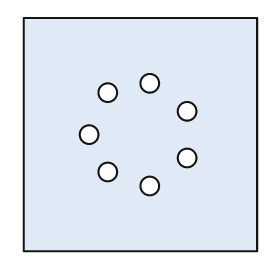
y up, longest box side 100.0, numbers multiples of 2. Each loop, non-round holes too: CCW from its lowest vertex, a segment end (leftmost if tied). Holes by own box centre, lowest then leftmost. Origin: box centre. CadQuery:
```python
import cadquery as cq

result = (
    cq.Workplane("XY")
    .moveTo(-50.0, -50.0)
    .lineTo(50.0, -50.0)
    .lineTo(50.0, 50.0)
    .lineTo(-50.0, 50.0)
    .close()
    .moveTo(4.0, -22.0)
    .circle(4.0)
    .moveTo(-14.0, -16.0)
    .circle(4.0)
    .moveTo(20.0, -10.0)
    .circle(4.0)
    .moveTo(-22.0, 0.0)
    .circle(4.0)
    .moveTo(20.0, 10.0)
    .circle(4.0)
    .moveTo(-14.0, 18.0)
    .circle(4.0)
    .moveTo(4.0, 22.0)
    .circle(4.0)
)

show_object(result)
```